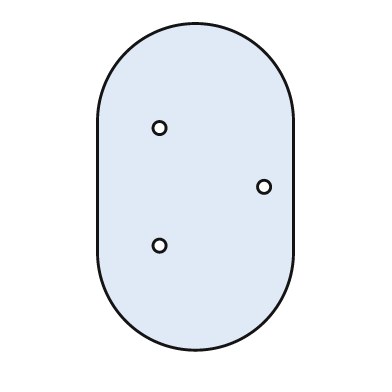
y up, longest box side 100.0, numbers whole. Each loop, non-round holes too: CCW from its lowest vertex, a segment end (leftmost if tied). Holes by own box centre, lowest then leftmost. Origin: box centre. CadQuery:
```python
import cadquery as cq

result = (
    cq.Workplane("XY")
    .moveTo(-30.0, -20.0)
    .threePointArc((0.0, -50.0), (30.0, -20.0))
    .lineTo(30.0, 20.0)
    .threePointArc((0.0, 50.0), (-30.0, 20.0))
    .close()
    .moveTo(-11.0, -18.0)
    .circle(2.0)
    .moveTo(21.0, 0.0)
    .circle(2.0)
    .moveTo(-11.0, 18.0)
    .circle(2.0)
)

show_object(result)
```